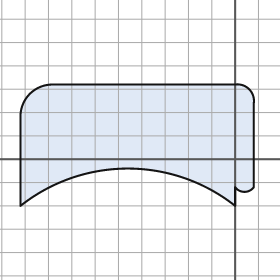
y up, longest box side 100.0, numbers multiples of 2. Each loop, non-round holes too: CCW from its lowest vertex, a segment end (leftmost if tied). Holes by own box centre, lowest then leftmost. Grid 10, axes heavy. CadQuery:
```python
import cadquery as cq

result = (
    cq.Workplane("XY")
    .moveTo(-92.0, -20.0)
    .threePointArc((-46.0, -4.0), (0.0, -20.0))
    .lineTo(0.0, -12.0)
    .threePointArc((4.0, -14.0), (8.0, -12.0))
    .lineTo(8.0, 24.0)
    .threePointArc((6.0, 30.0), (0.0, 32.0))
    .lineTo(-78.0, 32.0)
    .threePointArc((-88.0, 28.0), (-92.0, 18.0))
    .close()
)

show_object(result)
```